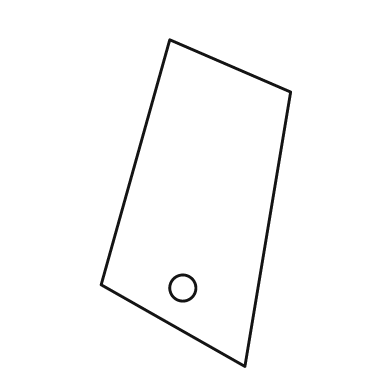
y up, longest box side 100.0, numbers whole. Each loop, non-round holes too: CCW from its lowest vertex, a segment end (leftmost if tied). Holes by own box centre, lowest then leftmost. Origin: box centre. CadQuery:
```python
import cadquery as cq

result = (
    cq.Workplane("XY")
    .moveTo(15.0, -50.0)
    .lineTo(29.0, 34.0)
    .lineTo(-8.0, 50.0)
    .lineTo(-29.0, -25.0)
    .close()
    .moveTo(-4.0, -26.0)
    .circle(4.0)
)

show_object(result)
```